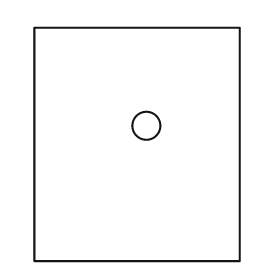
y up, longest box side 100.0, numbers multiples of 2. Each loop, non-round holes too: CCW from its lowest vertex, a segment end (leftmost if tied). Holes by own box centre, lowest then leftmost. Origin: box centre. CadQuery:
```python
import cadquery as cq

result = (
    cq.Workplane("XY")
    .moveTo(-44.0, -50.0)
    .lineTo(44.0, -50.0)
    .lineTo(44.0, 50.0)
    .lineTo(-44.0, 50.0)
    .close()
    .moveTo(4.0, 8.0)
    .circle(6.0)
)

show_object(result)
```